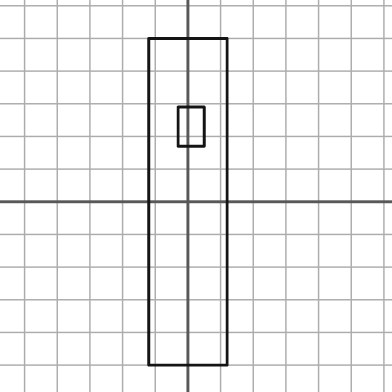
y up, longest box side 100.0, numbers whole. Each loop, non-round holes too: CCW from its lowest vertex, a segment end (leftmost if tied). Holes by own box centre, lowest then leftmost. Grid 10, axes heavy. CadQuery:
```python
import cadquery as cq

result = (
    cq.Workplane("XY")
    .moveTo(-12.0, -50.0)
    .lineTo(12.0, -50.0)
    .lineTo(12.0, 50.0)
    .lineTo(-12.0, 50.0)
    .close()
    .moveTo(-3.0, 17.0)
    .lineTo(5.0, 17.0)
    .lineTo(5.0, 29.0)
    .lineTo(-3.0, 29.0)
    .close()
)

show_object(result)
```